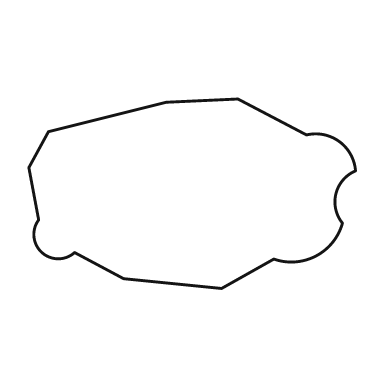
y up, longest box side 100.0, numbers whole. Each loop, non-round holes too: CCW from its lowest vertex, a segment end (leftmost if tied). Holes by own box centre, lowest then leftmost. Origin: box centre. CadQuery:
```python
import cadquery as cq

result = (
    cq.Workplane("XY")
    .moveTo(9.0, -29.0)
    .lineTo(25.0, -20.0)
    .threePointArc((38.0, -19.0), (46.0, -9.0))
    .threePointArc((44.0, 0.0), (50.0, 7.0))
    .threePointArc((45.0, 16.0), (35.0, 18.0))
    .lineTo(14.0, 29.0)
    .lineTo(-8.0, 28.0)
    .lineTo(-44.0, 19.0)
    .lineTo(-50.0, 8.0)
    .lineTo(-47.0, -8.0)
    .threePointArc((-46.0, -18.0), (-36.0, -18.0))
    .lineTo(-21.0, -26.0)
    .close()
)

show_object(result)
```